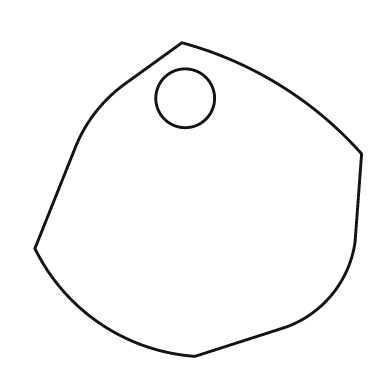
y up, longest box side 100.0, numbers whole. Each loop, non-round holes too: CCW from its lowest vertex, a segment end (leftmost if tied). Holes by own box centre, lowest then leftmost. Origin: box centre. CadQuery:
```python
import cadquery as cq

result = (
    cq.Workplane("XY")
    .moveTo(-1.0, -48.0)
    .lineTo(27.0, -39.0)
    .threePointArc((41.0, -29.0), (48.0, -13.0))
    .lineTo(50.0, 14.0)
    .threePointArc((25.0, 35.0), (-5.0, 48.0))
    .lineTo(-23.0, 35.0)
    .threePointArc((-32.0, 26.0), (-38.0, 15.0))
    .lineTo(-50.0, -15.0)
    .threePointArc((-30.0, -38.0), (-1.0, -48.0))
    .close()
    .moveTo(-4.0, 31.0)
    .circle(9.0)
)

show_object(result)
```